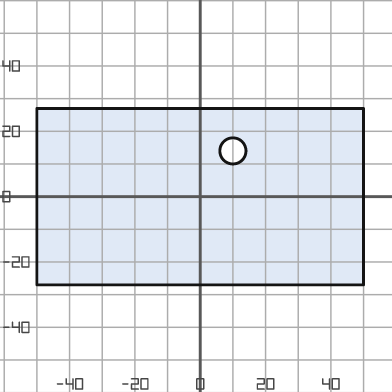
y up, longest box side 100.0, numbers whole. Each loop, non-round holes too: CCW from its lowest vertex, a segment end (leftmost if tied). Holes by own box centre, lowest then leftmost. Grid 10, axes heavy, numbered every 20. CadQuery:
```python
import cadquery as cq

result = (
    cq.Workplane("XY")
    .moveTo(-50.0, -27.0)
    .lineTo(50.0, -27.0)
    .lineTo(50.0, 27.0)
    .lineTo(-50.0, 27.0)
    .close()
    .moveTo(10.0, 14.0)
    .circle(4.0)
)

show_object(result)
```